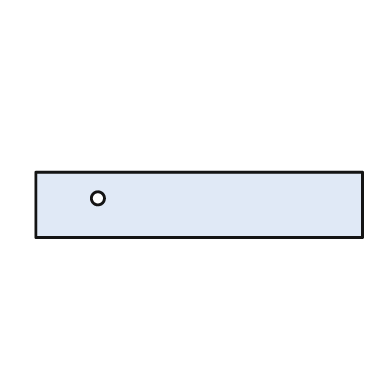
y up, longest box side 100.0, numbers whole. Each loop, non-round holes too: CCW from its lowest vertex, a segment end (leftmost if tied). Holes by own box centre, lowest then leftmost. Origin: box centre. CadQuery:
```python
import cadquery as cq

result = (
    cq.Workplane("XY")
    .moveTo(-50.0, -10.0)
    .lineTo(50.0, -10.0)
    .lineTo(50.0, 10.0)
    .lineTo(-50.0, 10.0)
    .close()
    .moveTo(-31.0, 2.0)
    .circle(2.0)
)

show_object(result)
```